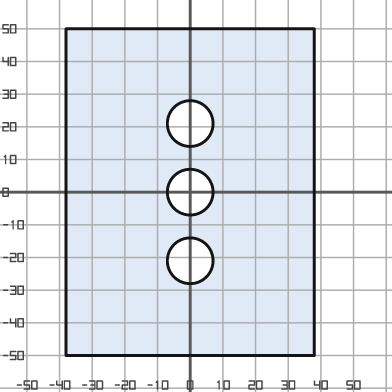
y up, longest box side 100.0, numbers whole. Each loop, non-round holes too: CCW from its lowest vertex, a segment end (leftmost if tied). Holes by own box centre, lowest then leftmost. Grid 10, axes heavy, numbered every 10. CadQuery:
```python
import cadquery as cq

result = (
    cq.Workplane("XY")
    .moveTo(-38.0, -50.0)
    .lineTo(38.0, -50.0)
    .lineTo(38.0, 50.0)
    .lineTo(-38.0, 50.0)
    .close()
    .moveTo(0.0, -21.0)
    .circle(7.0)
    .moveTo(0.0, 0.0)
    .circle(7.0)
    .moveTo(0.0, 21.0)
    .circle(7.0)
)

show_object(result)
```